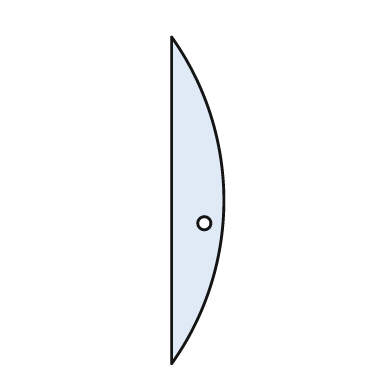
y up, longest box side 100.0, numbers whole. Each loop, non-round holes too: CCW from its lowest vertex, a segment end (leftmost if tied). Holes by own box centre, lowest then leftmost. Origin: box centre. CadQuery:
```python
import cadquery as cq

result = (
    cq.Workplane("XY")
    .moveTo(-8.0, -50.0)
    .threePointArc((8.0, 0.0), (-8.0, 50.0))
    .close()
    .moveTo(2.0, -7.0)
    .circle(2.0)
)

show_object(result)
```